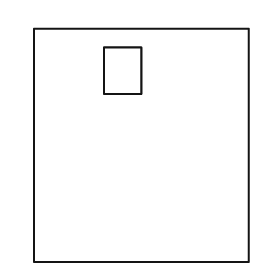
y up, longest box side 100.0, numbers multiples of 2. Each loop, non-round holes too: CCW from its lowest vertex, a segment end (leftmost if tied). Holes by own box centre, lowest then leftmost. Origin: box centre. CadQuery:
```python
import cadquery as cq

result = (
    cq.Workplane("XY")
    .moveTo(-46.0, -50.0)
    .lineTo(46.0, -50.0)
    .lineTo(46.0, 50.0)
    .lineTo(-46.0, 50.0)
    .close()
    .moveTo(-16.0, 22.0)
    .lineTo(0.0, 22.0)
    .lineTo(0.0, 42.0)
    .lineTo(-16.0, 42.0)
    .close()
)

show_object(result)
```